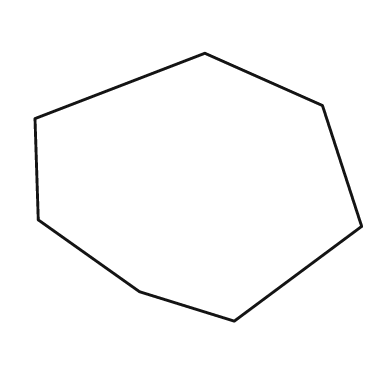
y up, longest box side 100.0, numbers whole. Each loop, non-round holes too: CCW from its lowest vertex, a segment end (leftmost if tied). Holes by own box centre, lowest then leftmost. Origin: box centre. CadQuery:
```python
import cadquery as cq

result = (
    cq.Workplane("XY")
    .moveTo(11.0, -41.0)
    .lineTo(50.0, -12.0)
    .lineTo(38.0, 25.0)
    .lineTo(2.0, 41.0)
    .lineTo(-50.0, 21.0)
    .lineTo(-49.0, -10.0)
    .lineTo(-18.0, -32.0)
    .close()
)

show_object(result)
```